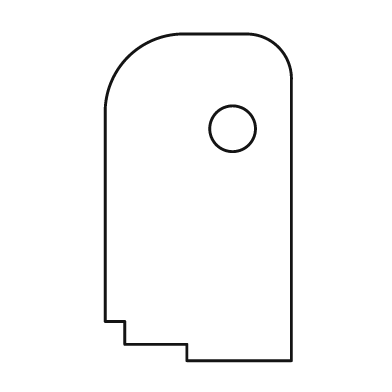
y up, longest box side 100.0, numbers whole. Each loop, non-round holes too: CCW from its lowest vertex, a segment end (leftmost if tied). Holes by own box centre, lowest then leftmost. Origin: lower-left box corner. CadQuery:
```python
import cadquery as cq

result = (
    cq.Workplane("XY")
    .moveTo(25.0, 0.0)
    .lineTo(57.0, 0.0)
    .lineTo(57.0, 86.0)
    .threePointArc((53.0, 96.0), (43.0, 100.0))
    .lineTo(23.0, 100.0)
    .threePointArc((7.0, 93.0), (0.0, 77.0))
    .lineTo(0.0, 12.0)
    .lineTo(6.0, 12.0)
    .lineTo(6.0, 5.0)
    .lineTo(25.0, 5.0)
    .close()
    .moveTo(39.0, 71.0)
    .circle(7.0)
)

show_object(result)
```